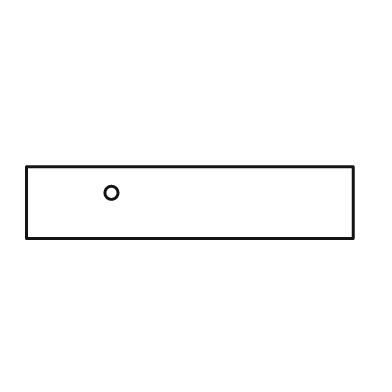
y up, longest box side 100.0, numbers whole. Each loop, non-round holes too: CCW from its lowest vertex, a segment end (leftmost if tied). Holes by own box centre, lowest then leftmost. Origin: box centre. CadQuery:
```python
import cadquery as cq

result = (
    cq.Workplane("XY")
    .moveTo(-50.0, -11.0)
    .lineTo(50.0, -11.0)
    .lineTo(50.0, 11.0)
    .lineTo(-50.0, 11.0)
    .close()
    .moveTo(-24.0, 3.0)
    .circle(2.0)
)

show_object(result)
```